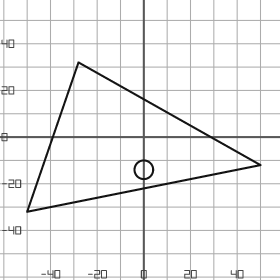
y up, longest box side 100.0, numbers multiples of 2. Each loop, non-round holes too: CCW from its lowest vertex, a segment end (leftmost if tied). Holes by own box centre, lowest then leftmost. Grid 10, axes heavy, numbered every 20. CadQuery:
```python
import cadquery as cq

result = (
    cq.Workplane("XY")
    .moveTo(-50.0, -32.0)
    .lineTo(50.0, -12.0)
    .lineTo(-28.0, 32.0)
    .close()
    .moveTo(0.0, -14.0)
    .circle(4.0)
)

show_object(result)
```